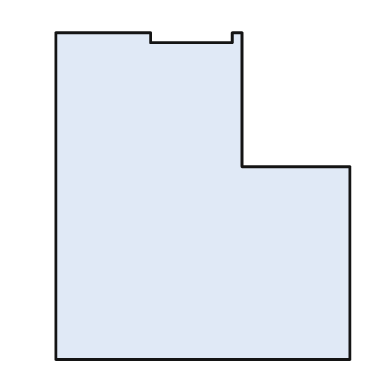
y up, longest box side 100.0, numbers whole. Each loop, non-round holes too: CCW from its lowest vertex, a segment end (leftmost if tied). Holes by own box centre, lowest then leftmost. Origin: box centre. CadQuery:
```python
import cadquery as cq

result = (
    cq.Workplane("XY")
    .moveTo(-45.0, -50.0)
    .lineTo(45.0, -50.0)
    .lineTo(45.0, 9.0)
    .lineTo(12.0, 9.0)
    .lineTo(12.0, 50.0)
    .lineTo(9.0, 50.0)
    .lineTo(9.0, 47.0)
    .lineTo(-16.0, 47.0)
    .lineTo(-16.0, 50.0)
    .lineTo(-45.0, 50.0)
    .close()
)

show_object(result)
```